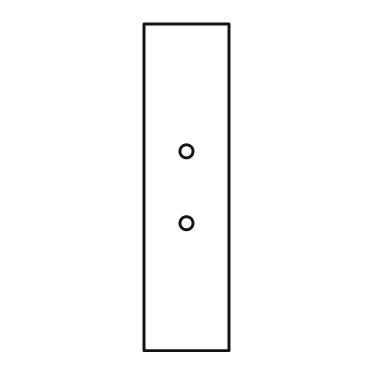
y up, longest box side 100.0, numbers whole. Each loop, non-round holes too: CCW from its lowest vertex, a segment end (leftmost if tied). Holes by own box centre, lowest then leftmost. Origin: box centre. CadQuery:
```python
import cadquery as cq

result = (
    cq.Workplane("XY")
    .moveTo(-13.0, -50.0)
    .lineTo(13.0, -50.0)
    .lineTo(13.0, 50.0)
    .lineTo(-13.0, 50.0)
    .close()
    .moveTo(0.0, -11.0)
    .circle(2.0)
    .moveTo(0.0, 11.0)
    .circle(2.0)
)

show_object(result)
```